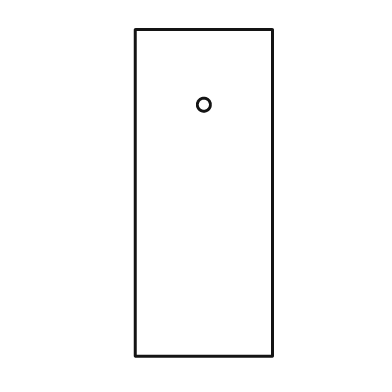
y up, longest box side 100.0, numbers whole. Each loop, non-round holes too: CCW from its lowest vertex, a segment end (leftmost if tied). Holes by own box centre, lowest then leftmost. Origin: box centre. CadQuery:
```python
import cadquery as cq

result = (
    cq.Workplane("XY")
    .moveTo(-21.0, -50.0)
    .lineTo(21.0, -50.0)
    .lineTo(21.0, 50.0)
    .lineTo(-21.0, 50.0)
    .close()
    .moveTo(0.0, 27.0)
    .circle(2.0)
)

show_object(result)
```